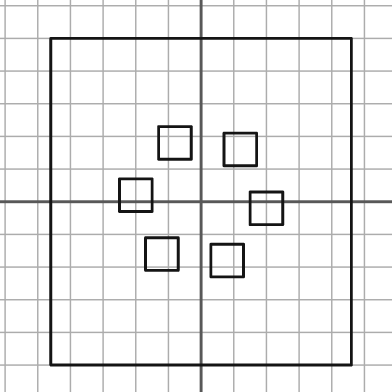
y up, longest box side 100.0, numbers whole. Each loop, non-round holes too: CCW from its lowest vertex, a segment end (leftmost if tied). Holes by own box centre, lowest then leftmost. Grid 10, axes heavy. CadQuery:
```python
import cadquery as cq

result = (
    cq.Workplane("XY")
    .moveTo(-46.0, -50.0)
    .lineTo(46.0, -50.0)
    .lineTo(46.0, 50.0)
    .lineTo(-46.0, 50.0)
    .close()
    .moveTo(3.0, -23.0)
    .lineTo(13.0, -23.0)
    .lineTo(13.0, -13.0)
    .lineTo(3.0, -13.0)
    .close()
    .moveTo(-17.0, -21.0)
    .lineTo(-7.0, -21.0)
    .lineTo(-7.0, -11.0)
    .lineTo(-17.0, -11.0)
    .close()
    .moveTo(15.0, -7.0)
    .lineTo(25.0, -7.0)
    .lineTo(25.0, 3.0)
    .lineTo(15.0, 3.0)
    .close()
    .moveTo(-25.0, -3.0)
    .lineTo(-15.0, -3.0)
    .lineTo(-15.0, 7.0)
    .lineTo(-25.0, 7.0)
    .close()
    .moveTo(7.0, 11.0)
    .lineTo(17.0, 11.0)
    .lineTo(17.0, 21.0)
    .lineTo(7.0, 21.0)
    .close()
    .moveTo(-13.0, 13.0)
    .lineTo(-3.0, 13.0)
    .lineTo(-3.0, 23.0)
    .lineTo(-13.0, 23.0)
    .close()
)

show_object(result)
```